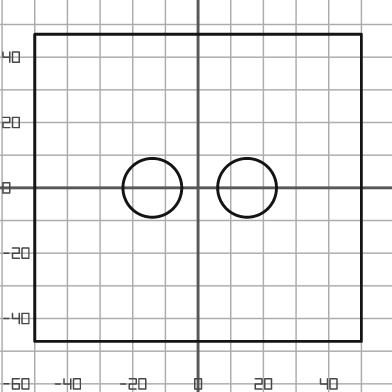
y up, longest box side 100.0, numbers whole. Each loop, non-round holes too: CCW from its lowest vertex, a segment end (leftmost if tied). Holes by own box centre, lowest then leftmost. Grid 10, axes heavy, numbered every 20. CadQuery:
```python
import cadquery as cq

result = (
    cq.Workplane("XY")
    .moveTo(-50.0, -47.0)
    .lineTo(50.0, -47.0)
    .lineTo(50.0, 47.0)
    .lineTo(-50.0, 47.0)
    .close()
    .moveTo(-14.0, 0.0)
    .circle(9.0)
    .moveTo(15.0, 0.0)
    .circle(9.0)
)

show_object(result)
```